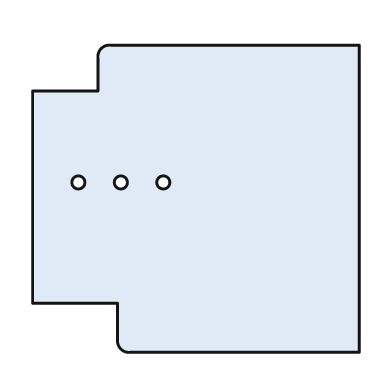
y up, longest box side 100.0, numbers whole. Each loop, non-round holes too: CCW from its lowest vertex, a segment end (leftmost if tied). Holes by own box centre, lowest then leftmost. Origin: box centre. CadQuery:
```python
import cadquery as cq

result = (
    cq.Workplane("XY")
    .moveTo(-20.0, -47.0)
    .lineTo(50.0, -47.0)
    .lineTo(50.0, 47.0)
    .lineTo(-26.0, 47.0)
    .threePointArc((-29.0, 46.0), (-30.0, 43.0))
    .lineTo(-30.0, 33.0)
    .lineTo(-50.0, 33.0)
    .lineTo(-50.0, -32.0)
    .lineTo(-24.0, -32.0)
    .lineTo(-24.0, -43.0)
    .threePointArc((-23.0, -46.0), (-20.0, -47.0))
    .close()
    .moveTo(-36.0, 5.0)
    .circle(2.0)
    .moveTo(-23.0, 5.0)
    .circle(2.0)
    .moveTo(-10.0, 5.0)
    .circle(2.0)
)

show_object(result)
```